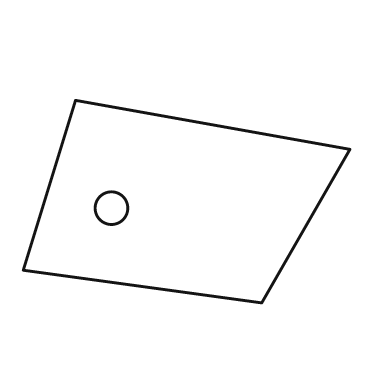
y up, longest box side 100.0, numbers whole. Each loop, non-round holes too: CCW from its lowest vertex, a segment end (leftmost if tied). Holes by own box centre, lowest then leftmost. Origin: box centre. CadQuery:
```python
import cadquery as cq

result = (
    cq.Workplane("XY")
    .moveTo(23.0, -31.0)
    .lineTo(50.0, 16.0)
    .lineTo(-34.0, 31.0)
    .lineTo(-50.0, -21.0)
    .close()
    .moveTo(-23.0, -2.0)
    .circle(5.0)
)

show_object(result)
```